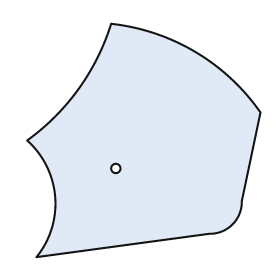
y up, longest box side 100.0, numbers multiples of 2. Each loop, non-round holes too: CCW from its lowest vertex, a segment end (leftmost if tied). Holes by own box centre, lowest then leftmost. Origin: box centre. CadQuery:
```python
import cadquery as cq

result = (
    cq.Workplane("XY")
    .moveTo(-46.0, -50.0)
    .lineTo(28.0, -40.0)
    .threePointArc((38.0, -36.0), (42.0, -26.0))
    .lineTo(50.0, 12.0)
    .threePointArc((22.0, 38.0), (-14.0, 50.0))
    .threePointArc((-28.0, 22.0), (-50.0, 0.0))
    .threePointArc((-38.0, -24.0), (-46.0, -50.0))
    .close()
    .moveTo(-12.0, -12.0)
    .circle(2.0)
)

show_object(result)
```